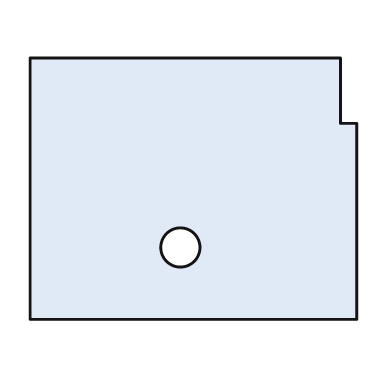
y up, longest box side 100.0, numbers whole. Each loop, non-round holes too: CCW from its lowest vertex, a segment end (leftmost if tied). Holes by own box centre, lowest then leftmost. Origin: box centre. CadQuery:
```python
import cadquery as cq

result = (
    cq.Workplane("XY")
    .moveTo(-50.0, -40.0)
    .lineTo(50.0, -40.0)
    .lineTo(50.0, 20.0)
    .lineTo(45.0, 20.0)
    .lineTo(45.0, 40.0)
    .lineTo(-50.0, 40.0)
    .close()
    .moveTo(-4.0, -18.0)
    .circle(6.0)
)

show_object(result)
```